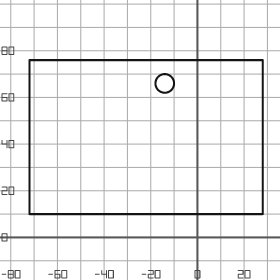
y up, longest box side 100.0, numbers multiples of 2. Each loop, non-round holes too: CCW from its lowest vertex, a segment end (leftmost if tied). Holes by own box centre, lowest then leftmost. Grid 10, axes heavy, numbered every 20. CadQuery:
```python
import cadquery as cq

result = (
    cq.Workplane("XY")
    .moveTo(-72.0, 10.0)
    .lineTo(28.0, 10.0)
    .lineTo(28.0, 76.0)
    .lineTo(-72.0, 76.0)
    .close()
    .moveTo(-14.0, 66.0)
    .circle(4.0)
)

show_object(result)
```